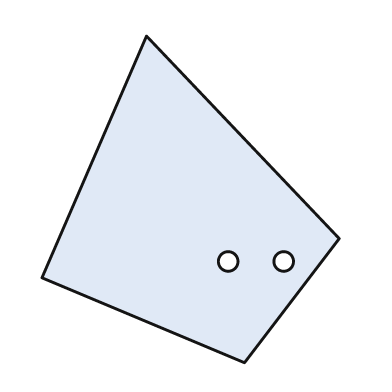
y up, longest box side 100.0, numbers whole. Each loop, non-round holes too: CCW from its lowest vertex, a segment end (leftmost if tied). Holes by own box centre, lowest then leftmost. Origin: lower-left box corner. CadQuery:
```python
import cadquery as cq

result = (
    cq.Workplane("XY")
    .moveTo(62.0, 0.0)
    .lineTo(91.0, 38.0)
    .lineTo(32.0, 100.0)
    .lineTo(0.0, 26.0)
    .close()
    .moveTo(57.0, 31.0)
    .circle(3.0)
    .moveTo(74.0, 31.0)
    .circle(3.0)
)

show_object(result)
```